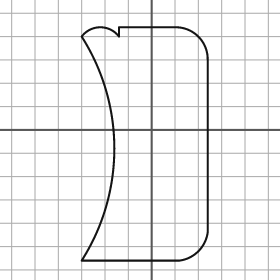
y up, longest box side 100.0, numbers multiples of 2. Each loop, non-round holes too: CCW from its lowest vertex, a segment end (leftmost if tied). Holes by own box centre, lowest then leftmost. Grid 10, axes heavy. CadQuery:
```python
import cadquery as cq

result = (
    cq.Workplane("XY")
    .moveTo(-30.0, -56.0)
    .lineTo(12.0, -56.0)
    .threePointArc((20.0, -52.0), (24.0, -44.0))
    .lineTo(24.0, 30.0)
    .threePointArc((20.0, 40.0), (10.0, 44.0))
    .lineTo(-14.0, 44.0)
    .lineTo(-14.0, 40.0)
    .threePointArc((-22.0, 44.0), (-30.0, 40.0))
    .threePointArc((-16.0, -8.0), (-30.0, -56.0))
    .close()
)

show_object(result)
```